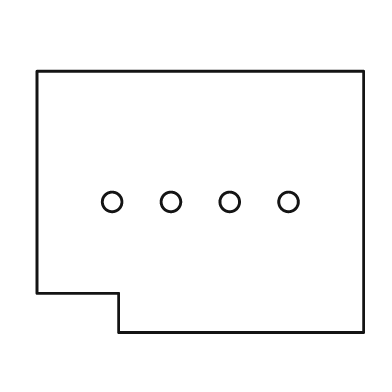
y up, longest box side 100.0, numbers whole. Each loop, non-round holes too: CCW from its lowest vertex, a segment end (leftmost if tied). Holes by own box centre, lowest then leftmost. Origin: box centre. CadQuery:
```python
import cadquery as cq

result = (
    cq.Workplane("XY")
    .moveTo(-25.0, -40.0)
    .lineTo(50.0, -40.0)
    .lineTo(50.0, 40.0)
    .lineTo(-50.0, 40.0)
    .lineTo(-50.0, -28.0)
    .lineTo(-25.0, -28.0)
    .close()
    .moveTo(-27.0, 0.0)
    .circle(3.0)
    .moveTo(-9.0, 0.0)
    .circle(3.0)
    .moveTo(9.0, 0.0)
    .circle(3.0)
    .moveTo(27.0, 0.0)
    .circle(3.0)
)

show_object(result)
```